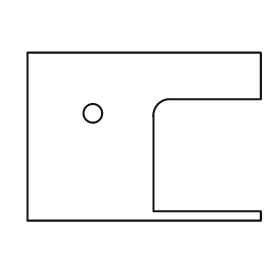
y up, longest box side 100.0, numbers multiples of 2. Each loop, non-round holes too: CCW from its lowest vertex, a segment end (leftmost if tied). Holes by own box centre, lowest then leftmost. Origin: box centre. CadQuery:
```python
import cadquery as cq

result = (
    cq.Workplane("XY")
    .moveTo(-50.0, -36.0)
    .lineTo(50.0, -36.0)
    .lineTo(50.0, -32.0)
    .lineTo(4.0, -32.0)
    .lineTo(4.0, 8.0)
    .threePointArc((6.0, 14.0), (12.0, 16.0))
    .lineTo(50.0, 16.0)
    .lineTo(50.0, 36.0)
    .lineTo(-50.0, 36.0)
    .close()
    .moveTo(-22.0, 10.0)
    .circle(4.0)
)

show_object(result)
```